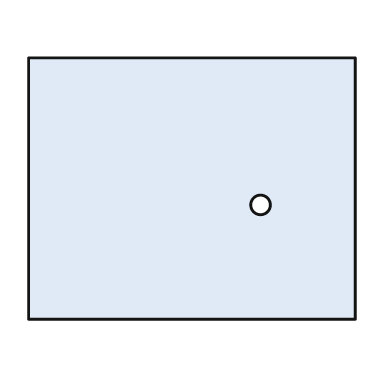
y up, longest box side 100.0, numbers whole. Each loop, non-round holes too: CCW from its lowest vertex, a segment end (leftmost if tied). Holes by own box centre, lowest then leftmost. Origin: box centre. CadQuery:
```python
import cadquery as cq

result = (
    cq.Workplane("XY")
    .moveTo(-50.0, -40.0)
    .lineTo(50.0, -40.0)
    .lineTo(50.0, 40.0)
    .lineTo(-50.0, 40.0)
    .close()
    .moveTo(21.0, -5.0)
    .circle(3.0)
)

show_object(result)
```